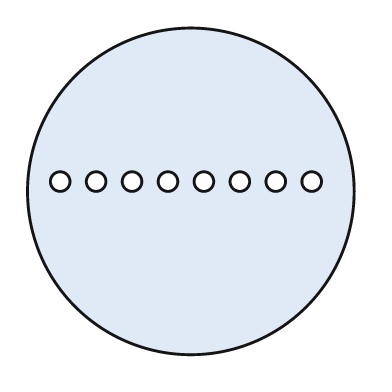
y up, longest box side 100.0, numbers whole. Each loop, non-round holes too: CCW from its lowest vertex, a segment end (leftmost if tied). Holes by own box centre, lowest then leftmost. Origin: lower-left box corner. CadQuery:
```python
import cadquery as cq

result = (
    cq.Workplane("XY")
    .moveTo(50.0, 50.0)
    .circle(50.0)
    .moveTo(10.0, 53.0)
    .circle(3.0)
    .moveTo(21.0, 53.0)
    .circle(3.0)
    .moveTo(32.0, 53.0)
    .circle(3.0)
    .moveTo(43.0, 53.0)
    .circle(3.0)
    .moveTo(54.0, 53.0)
    .circle(3.0)
    .moveTo(65.0, 53.0)
    .circle(3.0)
    .moveTo(76.0, 53.0)
    .circle(3.0)
    .moveTo(87.0, 53.0)
    .circle(3.0)
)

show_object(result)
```